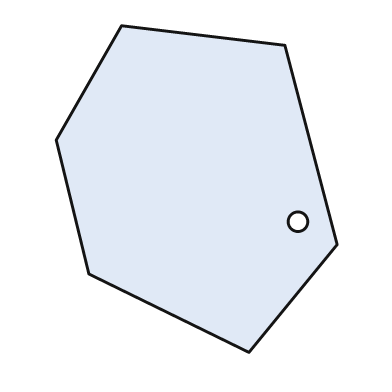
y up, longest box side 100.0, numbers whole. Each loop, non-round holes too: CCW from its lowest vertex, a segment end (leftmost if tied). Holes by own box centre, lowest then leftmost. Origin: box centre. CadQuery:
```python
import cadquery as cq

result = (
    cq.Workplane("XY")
    .moveTo(16.0, -50.0)
    .lineTo(43.0, -17.0)
    .lineTo(27.0, 44.0)
    .lineTo(-23.0, 50.0)
    .lineTo(-43.0, 15.0)
    .lineTo(-33.0, -26.0)
    .close()
    .moveTo(31.0, -10.0)
    .circle(3.0)
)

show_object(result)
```